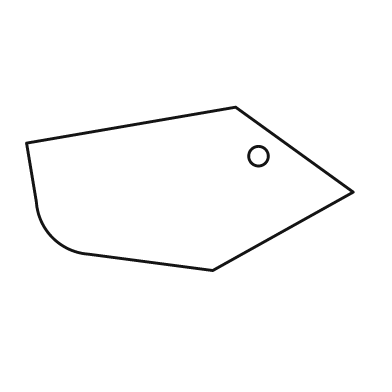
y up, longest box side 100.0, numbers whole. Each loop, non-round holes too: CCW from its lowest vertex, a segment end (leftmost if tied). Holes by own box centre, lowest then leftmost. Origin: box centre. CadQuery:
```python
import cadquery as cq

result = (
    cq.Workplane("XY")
    .moveTo(7.0, -25.0)
    .lineTo(50.0, -1.0)
    .lineTo(14.0, 25.0)
    .lineTo(-50.0, 14.0)
    .lineTo(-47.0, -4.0)
    .threePointArc((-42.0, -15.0), (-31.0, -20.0))
    .close()
    .moveTo(21.0, 10.0)
    .circle(3.0)
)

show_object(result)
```